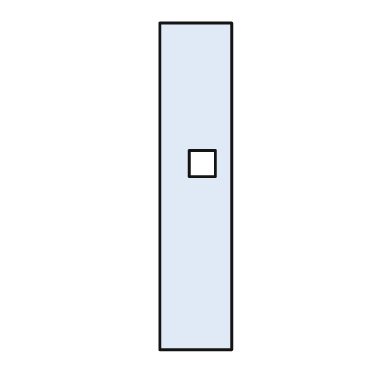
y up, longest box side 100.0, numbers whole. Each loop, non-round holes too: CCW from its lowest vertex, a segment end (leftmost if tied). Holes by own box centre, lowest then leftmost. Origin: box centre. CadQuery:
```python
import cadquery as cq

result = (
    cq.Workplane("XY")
    .moveTo(-11.0, -50.0)
    .lineTo(11.0, -50.0)
    .lineTo(11.0, 50.0)
    .lineTo(-11.0, 50.0)
    .close()
    .moveTo(-2.0, 3.0)
    .lineTo(6.0, 3.0)
    .lineTo(6.0, 11.0)
    .lineTo(-2.0, 11.0)
    .close()
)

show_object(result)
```